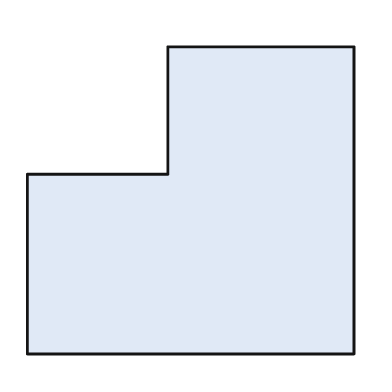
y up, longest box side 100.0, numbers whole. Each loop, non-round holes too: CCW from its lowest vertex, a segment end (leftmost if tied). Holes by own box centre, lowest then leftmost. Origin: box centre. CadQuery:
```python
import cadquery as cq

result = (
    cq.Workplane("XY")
    .moveTo(-50.0, -47.0)
    .lineTo(50.0, -47.0)
    .lineTo(50.0, 47.0)
    .lineTo(-7.0, 47.0)
    .lineTo(-7.0, 8.0)
    .lineTo(-50.0, 8.0)
    .close()
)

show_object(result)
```